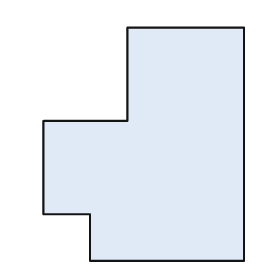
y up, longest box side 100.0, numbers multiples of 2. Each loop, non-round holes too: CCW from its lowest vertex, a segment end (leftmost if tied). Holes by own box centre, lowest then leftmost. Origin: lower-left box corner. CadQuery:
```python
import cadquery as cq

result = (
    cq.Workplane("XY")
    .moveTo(20.0, 0.0)
    .lineTo(86.0, 0.0)
    .lineTo(86.0, 100.0)
    .lineTo(36.0, 100.0)
    .lineTo(36.0, 60.0)
    .lineTo(0.0, 60.0)
    .lineTo(0.0, 20.0)
    .lineTo(20.0, 20.0)
    .close()
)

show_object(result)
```